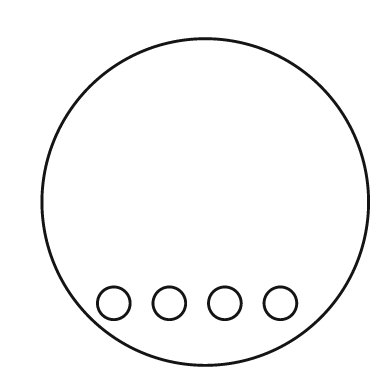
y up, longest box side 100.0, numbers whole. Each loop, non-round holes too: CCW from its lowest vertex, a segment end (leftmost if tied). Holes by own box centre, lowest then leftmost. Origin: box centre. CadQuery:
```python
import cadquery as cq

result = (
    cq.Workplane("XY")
    .moveTo(0.0, 0.0)
    .circle(50.0)
    .moveTo(-28.0, -31.0)
    .circle(5.0)
    .moveTo(-11.0, -31.0)
    .circle(5.0)
    .moveTo(6.0, -31.0)
    .circle(5.0)
    .moveTo(23.0, -31.0)
    .circle(5.0)
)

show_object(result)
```